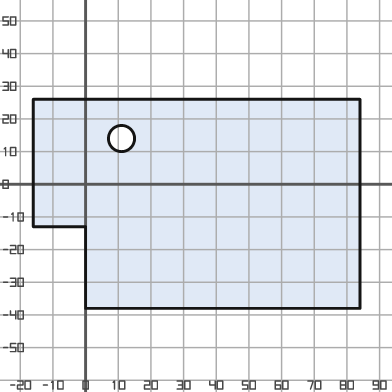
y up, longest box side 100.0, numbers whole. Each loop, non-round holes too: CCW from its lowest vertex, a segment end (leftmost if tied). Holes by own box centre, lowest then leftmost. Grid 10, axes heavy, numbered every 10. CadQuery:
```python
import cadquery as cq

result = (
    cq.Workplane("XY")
    .moveTo(0.0, -38.0)
    .lineTo(84.0, -38.0)
    .lineTo(84.0, 26.0)
    .lineTo(-16.0, 26.0)
    .lineTo(-16.0, -13.0)
    .lineTo(0.0, -13.0)
    .close()
    .moveTo(11.0, 14.0)
    .circle(4.0)
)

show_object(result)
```